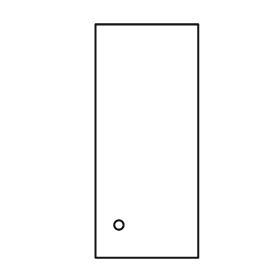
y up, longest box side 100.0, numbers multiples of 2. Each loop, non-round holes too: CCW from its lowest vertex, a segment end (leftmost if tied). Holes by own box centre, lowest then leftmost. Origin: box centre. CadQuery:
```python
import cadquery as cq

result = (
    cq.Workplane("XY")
    .moveTo(-22.0, -50.0)
    .lineTo(22.0, -50.0)
    .lineTo(22.0, 50.0)
    .lineTo(-22.0, 50.0)
    .close()
    .moveTo(-12.0, -36.0)
    .circle(2.0)
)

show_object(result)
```